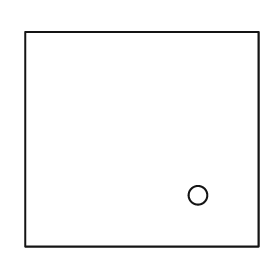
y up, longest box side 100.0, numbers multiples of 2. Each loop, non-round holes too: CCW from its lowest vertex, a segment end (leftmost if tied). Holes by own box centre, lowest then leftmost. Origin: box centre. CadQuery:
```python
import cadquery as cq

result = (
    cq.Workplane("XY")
    .moveTo(-50.0, -46.0)
    .lineTo(50.0, -46.0)
    .lineTo(50.0, 46.0)
    .lineTo(-50.0, 46.0)
    .close()
    .moveTo(24.0, -24.0)
    .circle(4.0)
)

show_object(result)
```